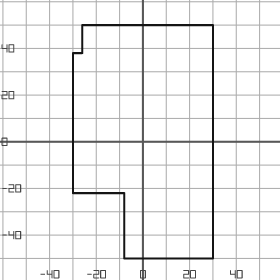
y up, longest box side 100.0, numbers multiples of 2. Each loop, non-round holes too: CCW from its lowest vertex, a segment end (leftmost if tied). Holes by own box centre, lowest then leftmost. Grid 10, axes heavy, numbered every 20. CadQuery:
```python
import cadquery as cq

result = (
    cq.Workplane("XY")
    .moveTo(-8.0, -50.0)
    .lineTo(30.0, -50.0)
    .lineTo(30.0, 50.0)
    .lineTo(-26.0, 50.0)
    .lineTo(-26.0, 38.0)
    .lineTo(-30.0, 38.0)
    .lineTo(-30.0, -22.0)
    .lineTo(-8.0, -22.0)
    .close()
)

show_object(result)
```